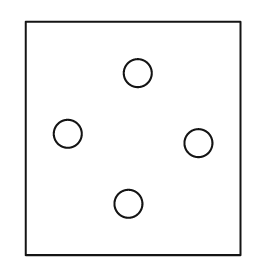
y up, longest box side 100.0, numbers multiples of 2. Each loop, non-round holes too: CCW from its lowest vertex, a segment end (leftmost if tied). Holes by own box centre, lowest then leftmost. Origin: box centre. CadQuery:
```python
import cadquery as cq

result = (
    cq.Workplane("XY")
    .moveTo(-46.0, -50.0)
    .lineTo(46.0, -50.0)
    .lineTo(46.0, 50.0)
    .lineTo(-46.0, 50.0)
    .close()
    .moveTo(-2.0, -28.0)
    .circle(6.0)
    .moveTo(28.0, -2.0)
    .circle(6.0)
    .moveTo(-28.0, 2.0)
    .circle(6.0)
    .moveTo(2.0, 28.0)
    .circle(6.0)
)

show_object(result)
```